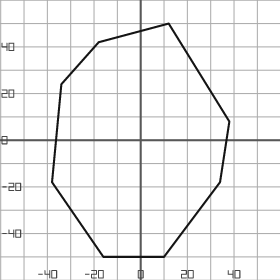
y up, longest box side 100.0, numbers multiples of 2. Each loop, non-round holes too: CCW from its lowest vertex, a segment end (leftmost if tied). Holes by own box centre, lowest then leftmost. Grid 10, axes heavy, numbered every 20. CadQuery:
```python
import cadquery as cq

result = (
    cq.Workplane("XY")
    .moveTo(-16.0, -50.0)
    .lineTo(10.0, -50.0)
    .lineTo(34.0, -18.0)
    .lineTo(38.0, 8.0)
    .lineTo(12.0, 50.0)
    .lineTo(-18.0, 42.0)
    .lineTo(-34.0, 24.0)
    .lineTo(-38.0, -18.0)
    .close()
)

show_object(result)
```